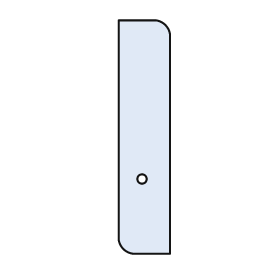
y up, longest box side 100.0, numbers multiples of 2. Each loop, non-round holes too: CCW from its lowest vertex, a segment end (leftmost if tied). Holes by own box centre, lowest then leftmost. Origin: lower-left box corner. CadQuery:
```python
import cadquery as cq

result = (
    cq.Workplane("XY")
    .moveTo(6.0, 0.0)
    .lineTo(22.0, 0.0)
    .lineTo(22.0, 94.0)
    .threePointArc((20.0, 98.0), (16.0, 100.0))
    .lineTo(0.0, 100.0)
    .lineTo(0.0, 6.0)
    .threePointArc((2.0, 2.0), (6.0, 0.0))
    .close()
    .moveTo(10.0, 32.0)
    .circle(2.0)
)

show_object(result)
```